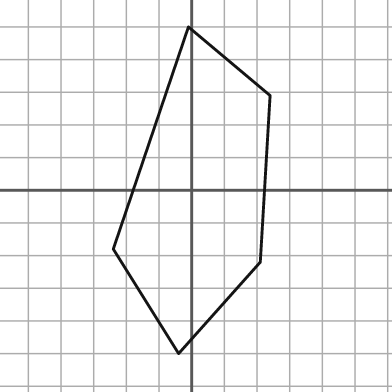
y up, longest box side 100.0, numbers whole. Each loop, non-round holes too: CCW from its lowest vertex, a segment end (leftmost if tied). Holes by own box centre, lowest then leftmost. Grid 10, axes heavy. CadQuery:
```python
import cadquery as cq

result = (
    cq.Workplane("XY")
    .moveTo(-4.0, -50.0)
    .lineTo(21.0, -22.0)
    .lineTo(24.0, 29.0)
    .lineTo(-1.0, 50.0)
    .lineTo(-24.0, -18.0)
    .close()
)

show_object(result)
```